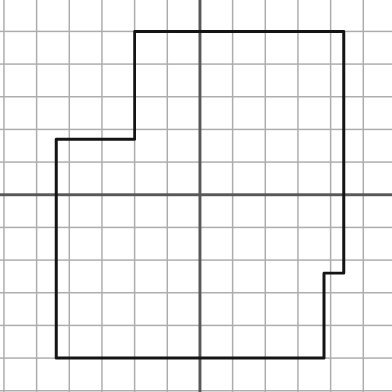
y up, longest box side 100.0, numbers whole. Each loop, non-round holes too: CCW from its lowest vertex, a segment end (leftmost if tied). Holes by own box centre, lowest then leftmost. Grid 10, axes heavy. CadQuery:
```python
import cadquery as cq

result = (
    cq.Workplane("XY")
    .moveTo(-44.0, -50.0)
    .lineTo(38.0, -50.0)
    .lineTo(38.0, -24.0)
    .lineTo(44.0, -24.0)
    .lineTo(44.0, 50.0)
    .lineTo(-20.0, 50.0)
    .lineTo(-20.0, 17.0)
    .lineTo(-44.0, 17.0)
    .close()
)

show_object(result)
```